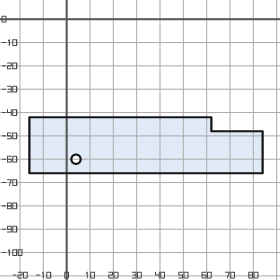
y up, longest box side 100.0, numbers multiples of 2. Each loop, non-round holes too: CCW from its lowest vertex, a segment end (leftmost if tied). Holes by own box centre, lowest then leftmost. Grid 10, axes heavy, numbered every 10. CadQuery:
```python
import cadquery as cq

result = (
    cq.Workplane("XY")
    .moveTo(-16.0, -66.0)
    .lineTo(84.0, -66.0)
    .lineTo(84.0, -48.0)
    .lineTo(62.0, -48.0)
    .lineTo(62.0, -42.0)
    .lineTo(-16.0, -42.0)
    .close()
    .moveTo(4.0, -60.0)
    .circle(2.0)
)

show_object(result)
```